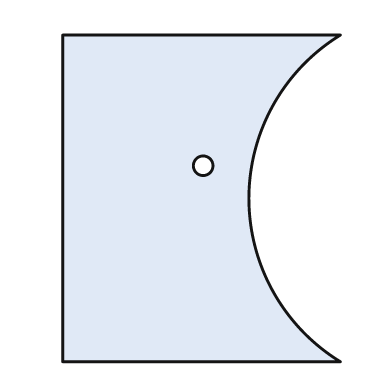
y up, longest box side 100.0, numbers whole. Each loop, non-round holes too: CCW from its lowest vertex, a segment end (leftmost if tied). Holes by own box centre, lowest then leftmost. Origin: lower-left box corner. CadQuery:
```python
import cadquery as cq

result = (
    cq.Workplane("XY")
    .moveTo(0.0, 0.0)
    .lineTo(85.0, 0.0)
    .threePointArc((57.0, 50.0), (85.0, 100.0))
    .lineTo(0.0, 100.0)
    .close()
    .moveTo(43.0, 60.0)
    .circle(3.0)
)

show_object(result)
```